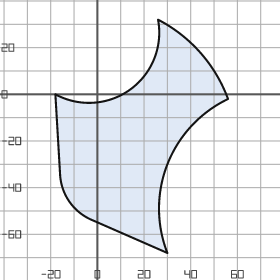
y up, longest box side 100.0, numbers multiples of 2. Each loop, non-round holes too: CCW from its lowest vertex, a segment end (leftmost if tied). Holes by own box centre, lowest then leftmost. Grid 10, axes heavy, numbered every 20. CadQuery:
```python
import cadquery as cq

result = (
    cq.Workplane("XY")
    .moveTo(30.0, -68.0)
    .threePointArc((30.0, -30.0), (56.0, -2.0))
    .threePointArc((44.0, 18.0), (26.0, 32.0))
    .threePointArc((14.0, 2.0), (-18.0, 0.0))
    .lineTo(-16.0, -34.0)
    .threePointArc((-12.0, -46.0), (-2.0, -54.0))
    .close()
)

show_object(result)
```